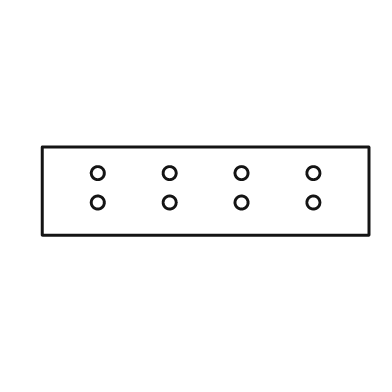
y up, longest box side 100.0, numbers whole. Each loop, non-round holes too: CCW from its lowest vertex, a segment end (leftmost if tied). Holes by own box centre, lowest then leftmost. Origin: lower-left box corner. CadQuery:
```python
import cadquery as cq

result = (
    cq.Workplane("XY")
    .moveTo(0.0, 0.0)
    .lineTo(100.0, 0.0)
    .lineTo(100.0, 27.0)
    .lineTo(0.0, 27.0)
    .close()
    .moveTo(17.0, 10.0)
    .circle(2.0)
    .moveTo(39.0, 10.0)
    .circle(2.0)
    .moveTo(61.0, 10.0)
    .circle(2.0)
    .moveTo(83.0, 10.0)
    .circle(2.0)
    .moveTo(17.0, 19.0)
    .circle(2.0)
    .moveTo(39.0, 19.0)
    .circle(2.0)
    .moveTo(61.0, 19.0)
    .circle(2.0)
    .moveTo(83.0, 19.0)
    .circle(2.0)
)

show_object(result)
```